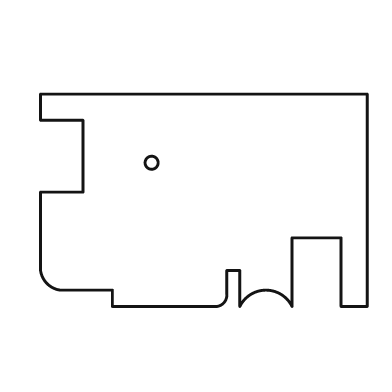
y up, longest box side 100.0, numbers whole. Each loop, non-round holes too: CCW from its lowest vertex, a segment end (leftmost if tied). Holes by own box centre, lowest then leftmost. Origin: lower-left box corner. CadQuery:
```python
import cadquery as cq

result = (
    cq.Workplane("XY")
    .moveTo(22.0, 0.0)
    .lineTo(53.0, 0.0)
    .threePointArc((56.0, 1.0), (57.0, 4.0))
    .lineTo(57.0, 11.0)
    .lineTo(61.0, 11.0)
    .lineTo(61.0, 0.0)
    .threePointArc((69.0, 5.0), (77.0, 0.0))
    .lineTo(77.0, 21.0)
    .lineTo(92.0, 21.0)
    .lineTo(92.0, 0.0)
    .lineTo(100.0, 0.0)
    .lineTo(100.0, 65.0)
    .lineTo(0.0, 65.0)
    .lineTo(0.0, 57.0)
    .lineTo(13.0, 57.0)
    .lineTo(13.0, 35.0)
    .lineTo(0.0, 35.0)
    .lineTo(0.0, 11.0)
    .threePointArc((2.0, 7.0), (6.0, 5.0))
    .lineTo(22.0, 5.0)
    .close()
    .moveTo(34.0, 44.0)
    .circle(2.0)
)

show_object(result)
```